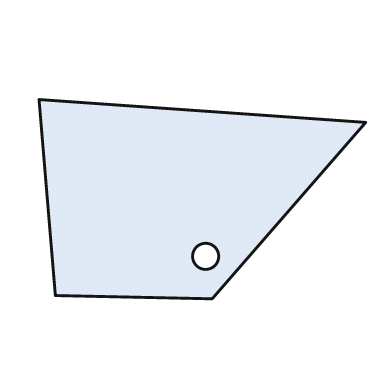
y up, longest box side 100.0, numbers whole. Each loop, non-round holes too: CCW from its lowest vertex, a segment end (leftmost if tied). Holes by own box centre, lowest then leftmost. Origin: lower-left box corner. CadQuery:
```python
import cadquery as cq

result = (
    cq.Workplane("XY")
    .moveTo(53.0, 0.0)
    .lineTo(100.0, 54.0)
    .lineTo(0.0, 61.0)
    .lineTo(5.0, 1.0)
    .close()
    .moveTo(51.0, 13.0)
    .circle(4.0)
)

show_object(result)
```